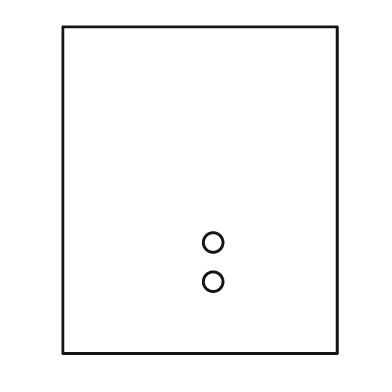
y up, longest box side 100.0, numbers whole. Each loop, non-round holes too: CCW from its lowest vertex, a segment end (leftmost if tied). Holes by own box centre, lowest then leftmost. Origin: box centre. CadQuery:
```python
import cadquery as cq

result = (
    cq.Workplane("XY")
    .moveTo(-42.0, -50.0)
    .lineTo(42.0, -50.0)
    .lineTo(42.0, 50.0)
    .lineTo(-42.0, 50.0)
    .close()
    .moveTo(4.0, -28.0)
    .circle(3.0)
    .moveTo(4.0, -16.0)
    .circle(3.0)
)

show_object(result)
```